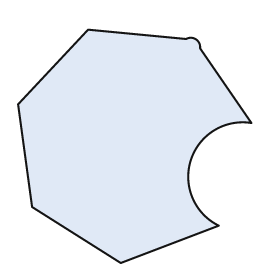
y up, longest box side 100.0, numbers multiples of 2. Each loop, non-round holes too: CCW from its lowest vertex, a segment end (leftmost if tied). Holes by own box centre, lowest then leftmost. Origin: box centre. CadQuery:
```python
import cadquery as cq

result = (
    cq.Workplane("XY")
    .moveTo(-6.0, -50.0)
    .lineTo(36.0, -34.0)
    .threePointArc((24.0, -6.0), (50.0, 10.0))
    .lineTo(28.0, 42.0)
    .threePointArc((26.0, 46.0), (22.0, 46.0))
    .lineTo(-20.0, 50.0)
    .lineTo(-50.0, 18.0)
    .lineTo(-44.0, -26.0)
    .close()
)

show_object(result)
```